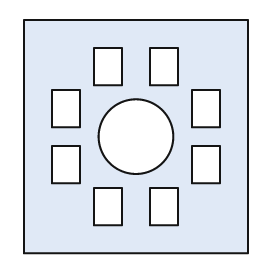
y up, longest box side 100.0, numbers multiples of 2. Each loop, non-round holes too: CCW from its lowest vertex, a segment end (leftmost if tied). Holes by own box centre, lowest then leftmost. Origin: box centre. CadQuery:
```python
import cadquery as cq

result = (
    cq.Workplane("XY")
    .moveTo(-48.0, -50.0)
    .lineTo(48.0, -50.0)
    .lineTo(48.0, 50.0)
    .lineTo(-48.0, 50.0)
    .close()
    .moveTo(-18.0, -38.0)
    .lineTo(-6.0, -38.0)
    .lineTo(-6.0, -22.0)
    .lineTo(-18.0, -22.0)
    .close()
    .moveTo(6.0, -38.0)
    .lineTo(18.0, -38.0)
    .lineTo(18.0, -22.0)
    .lineTo(6.0, -22.0)
    .close()
    .moveTo(-36.0, -20.0)
    .lineTo(-24.0, -20.0)
    .lineTo(-24.0, -4.0)
    .lineTo(-36.0, -4.0)
    .close()
    .moveTo(24.0, -20.0)
    .lineTo(36.0, -20.0)
    .lineTo(36.0, -4.0)
    .lineTo(24.0, -4.0)
    .close()
    .moveTo(0.0, 0.0)
    .circle(16.0)
    .moveTo(-36.0, 4.0)
    .lineTo(-24.0, 4.0)
    .lineTo(-24.0, 20.0)
    .lineTo(-36.0, 20.0)
    .close()
    .moveTo(24.0, 4.0)
    .lineTo(36.0, 4.0)
    .lineTo(36.0, 20.0)
    .lineTo(24.0, 20.0)
    .close()
    .moveTo(-18.0, 22.0)
    .lineTo(-6.0, 22.0)
    .lineTo(-6.0, 38.0)
    .lineTo(-18.0, 38.0)
    .close()
    .moveTo(6.0, 22.0)
    .lineTo(18.0, 22.0)
    .lineTo(18.0, 38.0)
    .lineTo(6.0, 38.0)
    .close()
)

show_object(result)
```